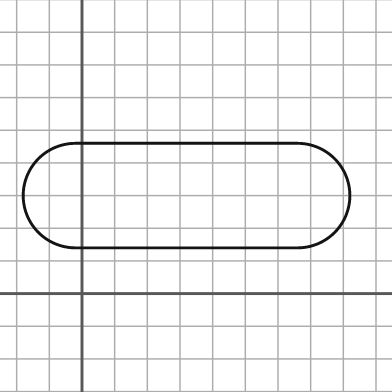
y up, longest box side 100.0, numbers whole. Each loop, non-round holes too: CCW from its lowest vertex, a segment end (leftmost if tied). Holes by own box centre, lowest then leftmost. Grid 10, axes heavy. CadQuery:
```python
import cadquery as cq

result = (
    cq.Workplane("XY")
    .moveTo(-2.0, 14.0)
    .lineTo(66.0, 14.0)
    .threePointArc((82.0, 30.0), (66.0, 46.0))
    .lineTo(-2.0, 46.0)
    .threePointArc((-18.0, 30.0), (-2.0, 14.0))
    .close()
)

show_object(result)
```